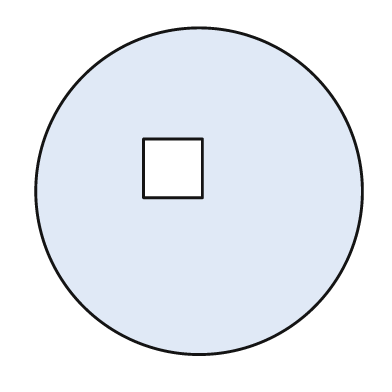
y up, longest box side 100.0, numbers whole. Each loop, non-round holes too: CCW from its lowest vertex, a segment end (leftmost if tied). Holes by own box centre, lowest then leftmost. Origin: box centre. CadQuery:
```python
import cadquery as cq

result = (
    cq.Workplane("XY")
    .moveTo(0.0, 0.0)
    .circle(50.0)
    .moveTo(-17.0, -2.0)
    .lineTo(1.0, -2.0)
    .lineTo(1.0, 16.0)
    .lineTo(-17.0, 16.0)
    .close()
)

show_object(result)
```